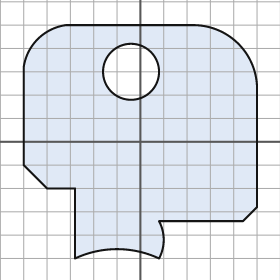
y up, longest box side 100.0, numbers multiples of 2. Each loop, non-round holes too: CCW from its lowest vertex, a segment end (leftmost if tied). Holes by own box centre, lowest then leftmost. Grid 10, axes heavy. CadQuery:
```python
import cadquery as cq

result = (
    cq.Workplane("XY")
    .moveTo(-28.0, -50.0)
    .threePointArc((-10.0, -46.0), (8.0, -50.0))
    .threePointArc((10.0, -42.0), (8.0, -34.0))
    .lineTo(44.0, -34.0)
    .lineTo(50.0, -28.0)
    .lineTo(50.0, 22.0)
    .threePointArc((42.0, 42.0), (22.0, 50.0))
    .lineTo(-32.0, 50.0)
    .threePointArc((-44.0, 44.0), (-50.0, 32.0))
    .lineTo(-50.0, -10.0)
    .lineTo(-40.0, -20.0)
    .lineTo(-28.0, -20.0)
    .close()
    .moveTo(-4.0, 30.0)
    .circle(12.0)
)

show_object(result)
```